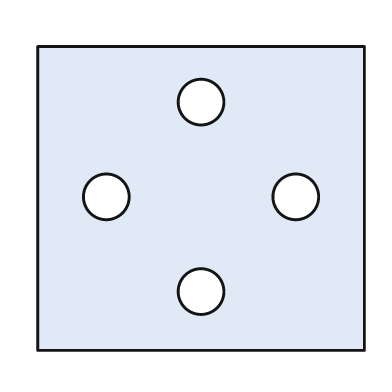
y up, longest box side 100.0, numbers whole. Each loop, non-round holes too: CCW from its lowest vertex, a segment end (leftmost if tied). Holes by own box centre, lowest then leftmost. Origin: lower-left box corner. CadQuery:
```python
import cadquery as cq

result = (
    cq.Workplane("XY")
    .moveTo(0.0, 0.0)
    .lineTo(100.0, 0.0)
    .lineTo(100.0, 93.0)
    .lineTo(0.0, 93.0)
    .close()
    .moveTo(50.0, 18.0)
    .circle(7.0)
    .moveTo(21.0, 47.0)
    .circle(7.0)
    .moveTo(79.0, 47.0)
    .circle(7.0)
    .moveTo(50.0, 76.0)
    .circle(7.0)
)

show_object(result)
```